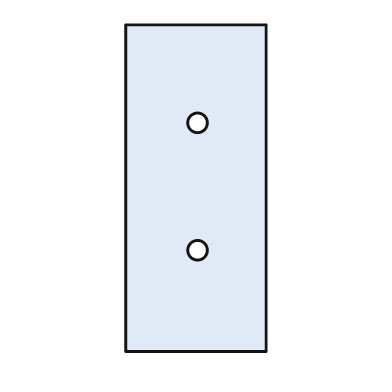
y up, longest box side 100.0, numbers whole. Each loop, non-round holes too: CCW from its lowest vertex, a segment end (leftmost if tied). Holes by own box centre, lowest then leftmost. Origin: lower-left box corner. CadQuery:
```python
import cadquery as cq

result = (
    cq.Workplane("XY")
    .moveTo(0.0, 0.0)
    .lineTo(43.0, 0.0)
    .lineTo(43.0, 100.0)
    .lineTo(0.0, 100.0)
    .close()
    .moveTo(22.0, 31.0)
    .circle(3.0)
    .moveTo(22.0, 70.0)
    .circle(3.0)
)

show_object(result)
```